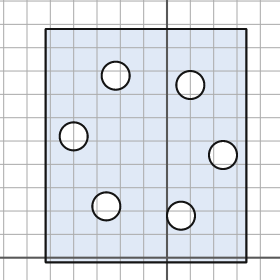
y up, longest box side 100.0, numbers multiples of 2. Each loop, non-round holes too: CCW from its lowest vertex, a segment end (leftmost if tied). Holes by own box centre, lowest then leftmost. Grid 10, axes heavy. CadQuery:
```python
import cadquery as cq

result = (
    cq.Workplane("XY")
    .moveTo(-52.0, -2.0)
    .lineTo(34.0, -2.0)
    .lineTo(34.0, 98.0)
    .lineTo(-52.0, 98.0)
    .close()
    .moveTo(6.0, 18.0)
    .circle(6.0)
    .moveTo(-26.0, 22.0)
    .circle(6.0)
    .moveTo(24.0, 44.0)
    .circle(6.0)
    .moveTo(-40.0, 52.0)
    .circle(6.0)
    .moveTo(10.0, 74.0)
    .circle(6.0)
    .moveTo(-22.0, 78.0)
    .circle(6.0)
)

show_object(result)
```